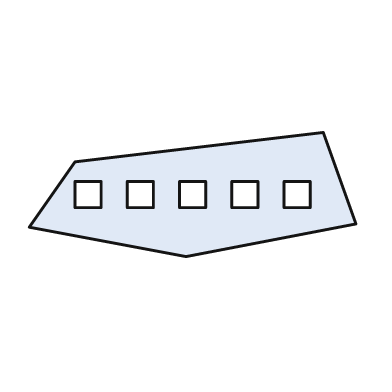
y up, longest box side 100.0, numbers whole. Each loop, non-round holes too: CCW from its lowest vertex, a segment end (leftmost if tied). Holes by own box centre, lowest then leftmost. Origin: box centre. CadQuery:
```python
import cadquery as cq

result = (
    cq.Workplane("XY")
    .moveTo(-2.0, -19.0)
    .lineTo(50.0, -9.0)
    .lineTo(40.0, 19.0)
    .lineTo(-36.0, 10.0)
    .lineTo(-50.0, -10.0)
    .close()
    .moveTo(-36.0, -4.0)
    .lineTo(-28.0, -4.0)
    .lineTo(-28.0, 4.0)
    .lineTo(-36.0, 4.0)
    .close()
    .moveTo(-20.0, -4.0)
    .lineTo(-12.0, -4.0)
    .lineTo(-12.0, 4.0)
    .lineTo(-20.0, 4.0)
    .close()
    .moveTo(-4.0, -4.0)
    .lineTo(4.0, -4.0)
    .lineTo(4.0, 4.0)
    .lineTo(-4.0, 4.0)
    .close()
    .moveTo(12.0, -4.0)
    .lineTo(20.0, -4.0)
    .lineTo(20.0, 4.0)
    .lineTo(12.0, 4.0)
    .close()
    .moveTo(28.0, -4.0)
    .lineTo(36.0, -4.0)
    .lineTo(36.0, 4.0)
    .lineTo(28.0, 4.0)
    .close()
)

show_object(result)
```